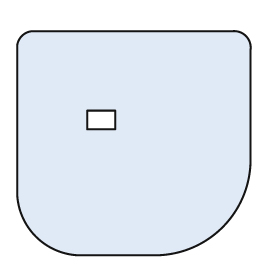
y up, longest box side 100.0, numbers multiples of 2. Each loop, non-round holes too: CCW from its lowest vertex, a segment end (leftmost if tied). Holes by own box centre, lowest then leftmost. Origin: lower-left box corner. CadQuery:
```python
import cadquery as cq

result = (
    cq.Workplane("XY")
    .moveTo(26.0, 0.0)
    .lineTo(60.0, 0.0)
    .threePointArc((88.0, 12.0), (100.0, 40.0))
    .lineTo(100.0, 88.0)
    .threePointArc((98.0, 94.0), (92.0, 96.0))
    .lineTo(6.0, 96.0)
    .threePointArc((2.0, 94.0), (0.0, 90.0))
    .lineTo(0.0, 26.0)
    .threePointArc((8.0, 8.0), (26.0, 0.0))
    .close()
    .moveTo(30.0, 54.0)
    .lineTo(42.0, 54.0)
    .lineTo(42.0, 62.0)
    .lineTo(30.0, 62.0)
    .close()
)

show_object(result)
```